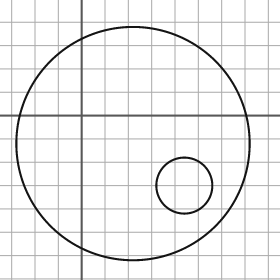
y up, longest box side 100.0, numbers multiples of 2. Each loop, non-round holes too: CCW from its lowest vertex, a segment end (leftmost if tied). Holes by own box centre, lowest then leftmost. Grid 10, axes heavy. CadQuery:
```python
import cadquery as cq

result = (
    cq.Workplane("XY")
    .moveTo(22.0, -12.0)
    .circle(50.0)
    .moveTo(44.0, -30.0)
    .circle(12.0)
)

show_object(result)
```